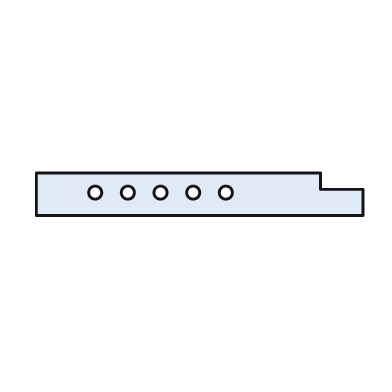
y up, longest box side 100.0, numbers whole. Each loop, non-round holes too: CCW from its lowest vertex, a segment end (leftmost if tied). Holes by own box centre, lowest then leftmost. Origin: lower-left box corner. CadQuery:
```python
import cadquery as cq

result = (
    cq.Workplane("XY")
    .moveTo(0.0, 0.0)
    .lineTo(100.0, 0.0)
    .lineTo(100.0, 8.0)
    .lineTo(87.0, 8.0)
    .lineTo(87.0, 13.0)
    .lineTo(0.0, 13.0)
    .close()
    .moveTo(18.0, 7.0)
    .circle(2.0)
    .moveTo(28.0, 7.0)
    .circle(2.0)
    .moveTo(38.0, 7.0)
    .circle(2.0)
    .moveTo(48.0, 7.0)
    .circle(2.0)
    .moveTo(58.0, 7.0)
    .circle(2.0)
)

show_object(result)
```